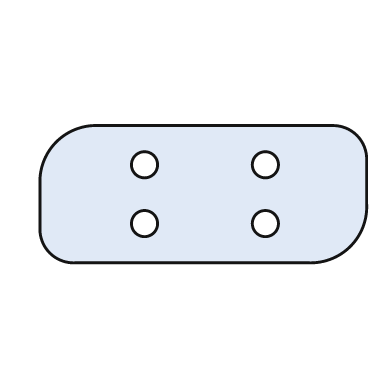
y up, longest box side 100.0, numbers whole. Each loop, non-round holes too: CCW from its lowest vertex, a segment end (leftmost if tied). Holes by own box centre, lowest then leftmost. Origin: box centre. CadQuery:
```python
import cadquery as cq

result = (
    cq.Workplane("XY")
    .moveTo(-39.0, -21.0)
    .lineTo(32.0, -21.0)
    .threePointArc((45.0, -16.0), (50.0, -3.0))
    .lineTo(50.0, 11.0)
    .threePointArc((47.0, 18.0), (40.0, 21.0))
    .lineTo(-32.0, 21.0)
    .threePointArc((-45.0, 16.0), (-50.0, 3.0))
    .lineTo(-50.0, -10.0)
    .threePointArc((-47.0, -18.0), (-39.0, -21.0))
    .close()
    .moveTo(-18.0, -9.0)
    .circle(4.0)
    .moveTo(19.0, -9.0)
    .circle(4.0)
    .moveTo(-18.0, 9.0)
    .circle(4.0)
    .moveTo(19.0, 9.0)
    .circle(4.0)
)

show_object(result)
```